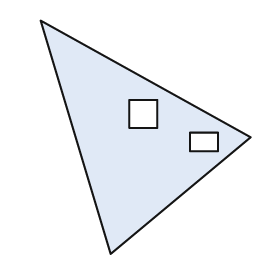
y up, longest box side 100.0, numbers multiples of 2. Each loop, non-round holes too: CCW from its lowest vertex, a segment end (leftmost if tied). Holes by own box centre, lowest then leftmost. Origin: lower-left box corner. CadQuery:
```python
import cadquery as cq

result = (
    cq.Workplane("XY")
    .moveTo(30.0, 0.0)
    .lineTo(90.0, 50.0)
    .lineTo(0.0, 100.0)
    .close()
    .moveTo(64.0, 44.0)
    .lineTo(76.0, 44.0)
    .lineTo(76.0, 52.0)
    .lineTo(64.0, 52.0)
    .close()
    .moveTo(38.0, 54.0)
    .lineTo(50.0, 54.0)
    .lineTo(50.0, 66.0)
    .lineTo(38.0, 66.0)
    .close()
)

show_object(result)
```